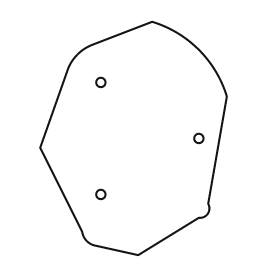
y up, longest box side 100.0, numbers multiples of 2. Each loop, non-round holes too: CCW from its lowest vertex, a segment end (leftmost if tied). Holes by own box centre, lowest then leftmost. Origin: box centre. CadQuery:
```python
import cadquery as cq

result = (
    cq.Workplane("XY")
    .moveTo(2.0, -50.0)
    .lineTo(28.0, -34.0)
    .threePointArc((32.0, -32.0), (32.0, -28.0))
    .lineTo(40.0, 18.0)
    .threePointArc((28.0, 38.0), (8.0, 50.0))
    .lineTo(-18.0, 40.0)
    .threePointArc((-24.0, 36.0), (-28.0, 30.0))
    .lineTo(-40.0, -4.0)
    .lineTo(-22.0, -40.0)
    .threePointArc((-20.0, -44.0), (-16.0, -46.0))
    .close()
    .moveTo(-14.0, -24.0)
    .circle(2.0)
    .moveTo(28.0, 0.0)
    .circle(2.0)
    .moveTo(-14.0, 24.0)
    .circle(2.0)
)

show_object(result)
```